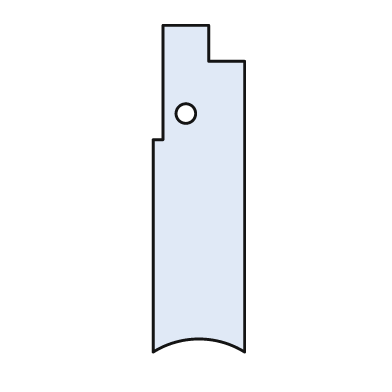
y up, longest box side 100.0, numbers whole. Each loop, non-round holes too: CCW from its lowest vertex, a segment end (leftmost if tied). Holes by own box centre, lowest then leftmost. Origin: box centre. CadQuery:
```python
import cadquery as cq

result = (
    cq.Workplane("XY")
    .moveTo(-14.0, -50.0)
    .threePointArc((0.0, -46.0), (14.0, -50.0))
    .lineTo(14.0, 39.0)
    .lineTo(3.0, 39.0)
    .lineTo(3.0, 50.0)
    .lineTo(-11.0, 50.0)
    .lineTo(-11.0, 15.0)
    .lineTo(-14.0, 15.0)
    .close()
    .moveTo(-4.0, 23.0)
    .circle(3.0)
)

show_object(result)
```